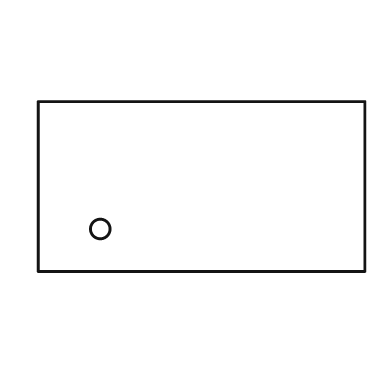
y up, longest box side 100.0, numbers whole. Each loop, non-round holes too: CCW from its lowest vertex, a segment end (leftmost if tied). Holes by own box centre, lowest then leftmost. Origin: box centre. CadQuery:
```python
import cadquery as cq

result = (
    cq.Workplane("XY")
    .moveTo(-50.0, -26.0)
    .lineTo(50.0, -26.0)
    .lineTo(50.0, 26.0)
    .lineTo(-50.0, 26.0)
    .close()
    .moveTo(-31.0, -13.0)
    .circle(3.0)
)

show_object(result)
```